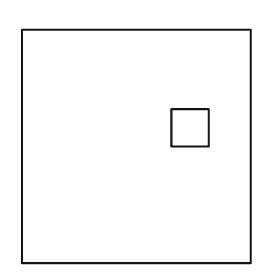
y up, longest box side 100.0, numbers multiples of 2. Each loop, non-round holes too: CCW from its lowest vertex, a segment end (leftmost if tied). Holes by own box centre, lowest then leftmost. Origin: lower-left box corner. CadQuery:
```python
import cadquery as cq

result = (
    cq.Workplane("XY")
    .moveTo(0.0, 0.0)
    .lineTo(98.0, 0.0)
    .lineTo(98.0, 100.0)
    .lineTo(0.0, 100.0)
    .close()
    .moveTo(64.0, 50.0)
    .lineTo(80.0, 50.0)
    .lineTo(80.0, 66.0)
    .lineTo(64.0, 66.0)
    .close()
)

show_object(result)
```